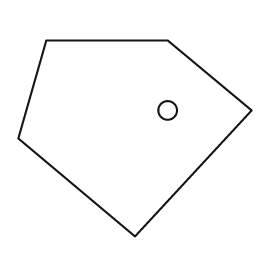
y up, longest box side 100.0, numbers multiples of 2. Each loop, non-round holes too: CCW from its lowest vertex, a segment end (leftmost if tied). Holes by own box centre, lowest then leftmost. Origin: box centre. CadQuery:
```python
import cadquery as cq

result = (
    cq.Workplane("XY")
    .moveTo(0.0, -42.0)
    .lineTo(50.0, 12.0)
    .lineTo(14.0, 42.0)
    .lineTo(-38.0, 42.0)
    .lineTo(-50.0, 0.0)
    .close()
    .moveTo(14.0, 12.0)
    .circle(4.0)
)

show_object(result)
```